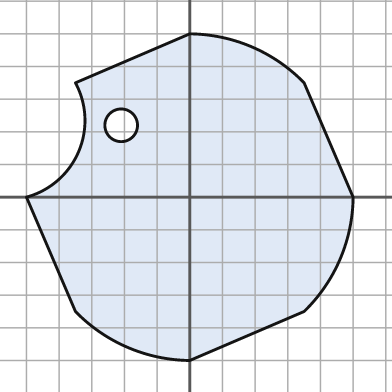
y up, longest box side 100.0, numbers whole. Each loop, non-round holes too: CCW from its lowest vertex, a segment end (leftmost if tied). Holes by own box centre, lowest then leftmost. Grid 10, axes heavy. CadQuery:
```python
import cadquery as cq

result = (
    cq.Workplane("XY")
    .moveTo(0.0, -50.0)
    .lineTo(35.0, -35.0)
    .threePointArc((46.0, -19.0), (50.0, 0.0))
    .lineTo(35.0, 35.0)
    .threePointArc((19.0, 46.0), (0.0, 50.0))
    .lineTo(-35.0, 35.0)
    .threePointArc((-34.0, 14.0), (-50.0, 0.0))
    .lineTo(-35.0, -35.0)
    .threePointArc((-19.0, -46.0), (0.0, -50.0))
    .close()
    .moveTo(-21.0, 22.0)
    .circle(5.0)
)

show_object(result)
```